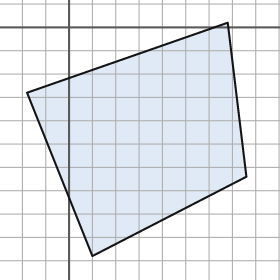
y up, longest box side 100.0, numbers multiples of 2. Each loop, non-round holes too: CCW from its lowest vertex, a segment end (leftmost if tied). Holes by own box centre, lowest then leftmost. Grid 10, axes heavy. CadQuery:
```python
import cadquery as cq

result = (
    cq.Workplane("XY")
    .moveTo(10.0, -98.0)
    .lineTo(76.0, -64.0)
    .lineTo(68.0, 2.0)
    .lineTo(-18.0, -28.0)
    .close()
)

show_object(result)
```